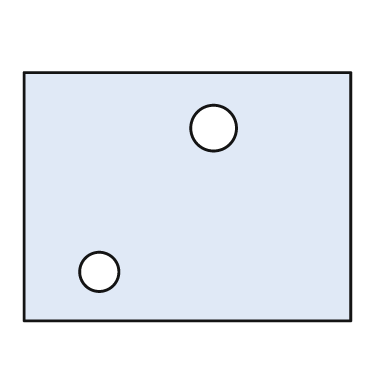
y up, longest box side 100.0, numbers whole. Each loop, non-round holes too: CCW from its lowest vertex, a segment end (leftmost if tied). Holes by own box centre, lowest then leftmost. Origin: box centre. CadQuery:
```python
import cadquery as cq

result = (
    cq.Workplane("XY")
    .moveTo(-50.0, -38.0)
    .lineTo(50.0, -38.0)
    .lineTo(50.0, 38.0)
    .lineTo(-50.0, 38.0)
    .close()
    .moveTo(-27.0, -23.0)
    .circle(6.0)
    .moveTo(8.0, 21.0)
    .circle(7.0)
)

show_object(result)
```